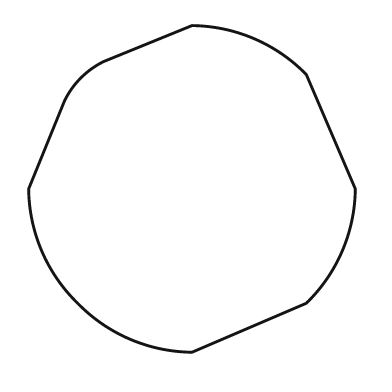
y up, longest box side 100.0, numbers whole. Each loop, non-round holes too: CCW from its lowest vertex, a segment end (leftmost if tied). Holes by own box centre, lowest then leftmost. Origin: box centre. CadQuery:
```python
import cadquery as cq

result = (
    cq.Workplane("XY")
    .moveTo(0.0, -50.0)
    .lineTo(35.0, -35.0)
    .threePointArc((46.0, -19.0), (50.0, 0.0))
    .lineTo(35.0, 35.0)
    .threePointArc((19.0, 46.0), (0.0, 50.0))
    .lineTo(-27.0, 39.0)
    .threePointArc((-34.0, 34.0), (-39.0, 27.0))
    .lineTo(-50.0, 0.0)
    .threePointArc((-46.0, -19.0), (-35.0, -35.0))
    .threePointArc((-19.0, -46.0), (0.0, -50.0))
    .close()
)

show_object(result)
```